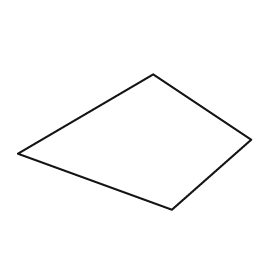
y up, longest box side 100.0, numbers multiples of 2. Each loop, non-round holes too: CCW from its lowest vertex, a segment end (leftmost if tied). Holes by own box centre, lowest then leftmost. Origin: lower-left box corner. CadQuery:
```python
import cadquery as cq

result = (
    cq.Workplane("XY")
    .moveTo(66.0, 0.0)
    .lineTo(100.0, 30.0)
    .lineTo(58.0, 58.0)
    .lineTo(0.0, 24.0)
    .close()
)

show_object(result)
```